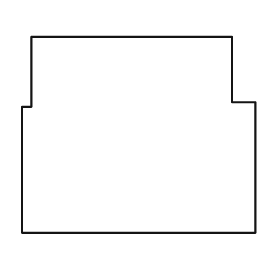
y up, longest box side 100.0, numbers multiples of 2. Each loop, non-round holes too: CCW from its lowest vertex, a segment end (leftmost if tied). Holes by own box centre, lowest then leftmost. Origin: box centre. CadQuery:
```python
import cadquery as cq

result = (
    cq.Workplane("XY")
    .moveTo(-50.0, -42.0)
    .lineTo(50.0, -42.0)
    .lineTo(50.0, 14.0)
    .lineTo(40.0, 14.0)
    .lineTo(40.0, 42.0)
    .lineTo(-46.0, 42.0)
    .lineTo(-46.0, 12.0)
    .lineTo(-50.0, 12.0)
    .close()
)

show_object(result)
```